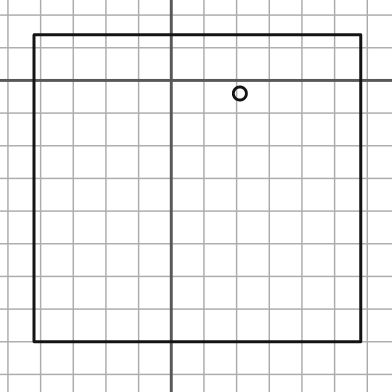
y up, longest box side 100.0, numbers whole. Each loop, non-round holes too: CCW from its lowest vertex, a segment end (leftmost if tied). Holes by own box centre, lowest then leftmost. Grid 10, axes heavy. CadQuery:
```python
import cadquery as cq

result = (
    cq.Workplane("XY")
    .moveTo(-42.0, -80.0)
    .lineTo(58.0, -80.0)
    .lineTo(58.0, 14.0)
    .lineTo(-42.0, 14.0)
    .close()
    .moveTo(21.0, -4.0)
    .circle(2.0)
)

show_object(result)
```